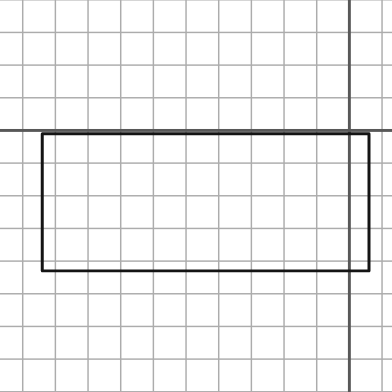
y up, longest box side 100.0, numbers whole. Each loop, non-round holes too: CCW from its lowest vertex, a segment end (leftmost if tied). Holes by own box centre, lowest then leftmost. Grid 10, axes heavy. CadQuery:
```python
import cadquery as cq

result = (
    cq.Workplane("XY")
    .moveTo(-94.0, -43.0)
    .lineTo(6.0, -43.0)
    .lineTo(6.0, -1.0)
    .lineTo(-94.0, -1.0)
    .close()
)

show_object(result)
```